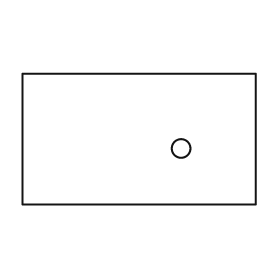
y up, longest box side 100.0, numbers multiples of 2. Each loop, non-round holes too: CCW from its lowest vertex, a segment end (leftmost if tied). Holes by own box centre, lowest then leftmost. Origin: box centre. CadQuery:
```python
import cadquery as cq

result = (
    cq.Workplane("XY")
    .moveTo(-50.0, -28.0)
    .lineTo(50.0, -28.0)
    .lineTo(50.0, 28.0)
    .lineTo(-50.0, 28.0)
    .close()
    .moveTo(18.0, -4.0)
    .circle(4.0)
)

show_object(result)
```